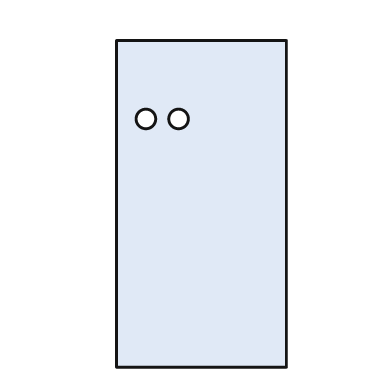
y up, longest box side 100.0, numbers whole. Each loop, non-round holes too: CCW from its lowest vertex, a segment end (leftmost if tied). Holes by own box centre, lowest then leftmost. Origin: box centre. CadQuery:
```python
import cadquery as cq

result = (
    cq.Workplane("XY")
    .moveTo(-26.0, -50.0)
    .lineTo(26.0, -50.0)
    .lineTo(26.0, 50.0)
    .lineTo(-26.0, 50.0)
    .close()
    .moveTo(-17.0, 26.0)
    .circle(3.0)
    .moveTo(-7.0, 26.0)
    .circle(3.0)
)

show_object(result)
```